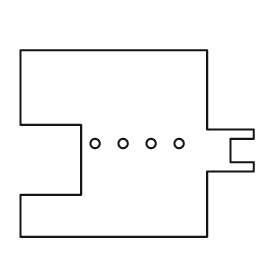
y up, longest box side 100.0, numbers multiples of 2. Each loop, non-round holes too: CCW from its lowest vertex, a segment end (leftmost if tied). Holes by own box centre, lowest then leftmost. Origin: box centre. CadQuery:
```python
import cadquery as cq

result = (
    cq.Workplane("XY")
    .moveTo(-50.0, -40.0)
    .lineTo(30.0, -40.0)
    .lineTo(30.0, -12.0)
    .lineTo(50.0, -12.0)
    .lineTo(50.0, -8.0)
    .lineTo(40.0, -8.0)
    .lineTo(40.0, 2.0)
    .lineTo(50.0, 2.0)
    .lineTo(50.0, 6.0)
    .lineTo(30.0, 6.0)
    .lineTo(30.0, 40.0)
    .lineTo(-50.0, 40.0)
    .lineTo(-50.0, 8.0)
    .lineTo(-24.0, 8.0)
    .lineTo(-24.0, -22.0)
    .lineTo(-50.0, -22.0)
    .close()
    .moveTo(-18.0, 0.0)
    .circle(2.0)
    .moveTo(-6.0, 0.0)
    .circle(2.0)
    .moveTo(6.0, 0.0)
    .circle(2.0)
    .moveTo(18.0, 0.0)
    .circle(2.0)
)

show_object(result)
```